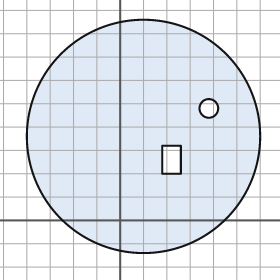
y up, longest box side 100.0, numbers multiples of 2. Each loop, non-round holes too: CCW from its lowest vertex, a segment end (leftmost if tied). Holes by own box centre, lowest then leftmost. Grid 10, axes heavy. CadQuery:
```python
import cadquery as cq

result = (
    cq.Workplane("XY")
    .moveTo(10.0, 36.0)
    .circle(50.0)
    .moveTo(18.0, 20.0)
    .lineTo(26.0, 20.0)
    .lineTo(26.0, 32.0)
    .lineTo(18.0, 32.0)
    .close()
    .moveTo(38.0, 48.0)
    .circle(4.0)
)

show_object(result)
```